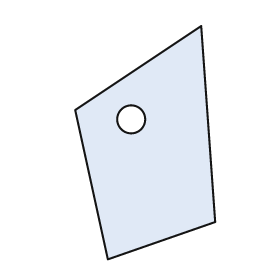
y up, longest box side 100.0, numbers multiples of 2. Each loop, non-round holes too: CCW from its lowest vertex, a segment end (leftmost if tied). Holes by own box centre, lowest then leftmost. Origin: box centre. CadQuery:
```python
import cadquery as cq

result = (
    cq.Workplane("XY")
    .moveTo(-16.0, -50.0)
    .lineTo(30.0, -34.0)
    .lineTo(24.0, 50.0)
    .lineTo(-30.0, 14.0)
    .close()
    .moveTo(-6.0, 10.0)
    .circle(6.0)
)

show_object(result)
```